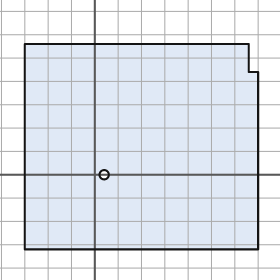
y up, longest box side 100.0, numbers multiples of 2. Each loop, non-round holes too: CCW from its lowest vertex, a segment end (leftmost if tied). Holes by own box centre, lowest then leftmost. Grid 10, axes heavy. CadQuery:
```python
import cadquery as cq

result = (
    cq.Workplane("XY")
    .moveTo(-30.0, -32.0)
    .lineTo(70.0, -32.0)
    .lineTo(70.0, 44.0)
    .lineTo(66.0, 44.0)
    .lineTo(66.0, 56.0)
    .lineTo(-30.0, 56.0)
    .close()
    .moveTo(4.0, 0.0)
    .circle(2.0)
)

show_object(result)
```